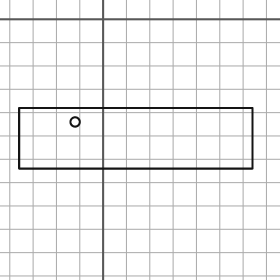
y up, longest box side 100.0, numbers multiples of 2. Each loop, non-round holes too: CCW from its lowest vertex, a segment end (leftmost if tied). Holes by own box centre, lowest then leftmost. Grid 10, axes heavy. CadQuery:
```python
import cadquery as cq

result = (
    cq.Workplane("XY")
    .moveTo(-36.0, -64.0)
    .lineTo(64.0, -64.0)
    .lineTo(64.0, -38.0)
    .lineTo(-36.0, -38.0)
    .close()
    .moveTo(-12.0, -44.0)
    .circle(2.0)
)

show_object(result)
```